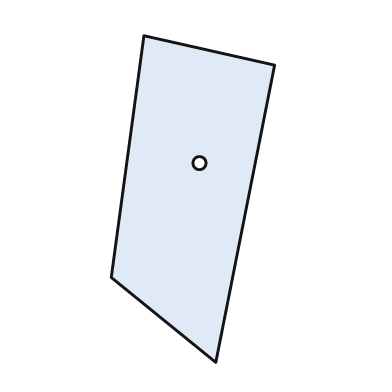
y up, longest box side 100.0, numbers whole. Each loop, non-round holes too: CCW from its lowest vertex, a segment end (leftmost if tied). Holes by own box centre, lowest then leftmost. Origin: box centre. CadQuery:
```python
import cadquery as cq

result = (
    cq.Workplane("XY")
    .moveTo(7.0, -50.0)
    .lineTo(25.0, 41.0)
    .lineTo(-15.0, 50.0)
    .lineTo(-25.0, -24.0)
    .close()
    .moveTo(2.0, 11.0)
    .circle(2.0)
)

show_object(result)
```